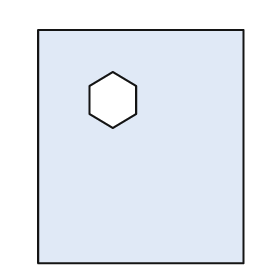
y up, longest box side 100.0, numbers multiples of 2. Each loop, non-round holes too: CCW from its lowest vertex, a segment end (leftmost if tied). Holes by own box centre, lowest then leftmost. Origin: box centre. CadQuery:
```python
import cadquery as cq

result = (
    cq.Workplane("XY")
    .moveTo(-44.0, -50.0)
    .lineTo(44.0, -50.0)
    .lineTo(44.0, 50.0)
    .lineTo(-44.0, 50.0)
    .close()
    .moveTo(-12.0, 8.0)
    .lineTo(-2.0, 14.0)
    .lineTo(-2.0, 26.0)
    .lineTo(-12.0, 32.0)
    .lineTo(-22.0, 26.0)
    .lineTo(-22.0, 14.0)
    .close()
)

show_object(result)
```